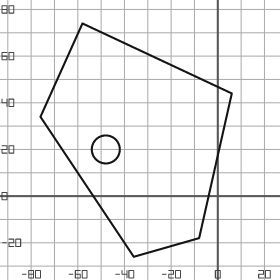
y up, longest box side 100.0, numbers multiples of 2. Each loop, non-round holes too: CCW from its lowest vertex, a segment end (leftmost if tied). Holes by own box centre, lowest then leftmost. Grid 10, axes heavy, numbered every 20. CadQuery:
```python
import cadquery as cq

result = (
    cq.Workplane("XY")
    .moveTo(-36.0, -26.0)
    .lineTo(-8.0, -18.0)
    .lineTo(6.0, 44.0)
    .lineTo(-58.0, 74.0)
    .lineTo(-76.0, 34.0)
    .close()
    .moveTo(-48.0, 20.0)
    .circle(6.0)
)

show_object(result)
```